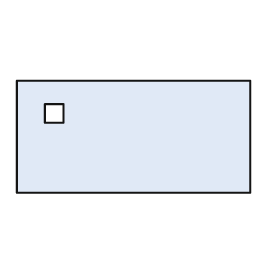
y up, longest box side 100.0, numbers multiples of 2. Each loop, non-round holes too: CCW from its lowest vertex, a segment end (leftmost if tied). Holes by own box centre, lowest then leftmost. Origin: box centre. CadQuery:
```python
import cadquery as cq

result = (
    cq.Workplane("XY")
    .moveTo(-50.0, -24.0)
    .lineTo(50.0, -24.0)
    .lineTo(50.0, 24.0)
    .lineTo(-50.0, 24.0)
    .close()
    .moveTo(-38.0, 6.0)
    .lineTo(-30.0, 6.0)
    .lineTo(-30.0, 14.0)
    .lineTo(-38.0, 14.0)
    .close()
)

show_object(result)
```